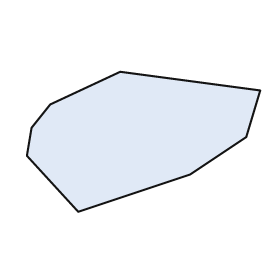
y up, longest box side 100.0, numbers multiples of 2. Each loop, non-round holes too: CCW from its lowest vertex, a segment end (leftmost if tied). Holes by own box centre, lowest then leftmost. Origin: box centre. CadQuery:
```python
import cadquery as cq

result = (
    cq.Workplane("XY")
    .moveTo(-28.0, -30.0)
    .lineTo(20.0, -14.0)
    .lineTo(44.0, 2.0)
    .lineTo(50.0, 22.0)
    .lineTo(-10.0, 30.0)
    .lineTo(-40.0, 16.0)
    .lineTo(-48.0, 6.0)
    .lineTo(-50.0, -6.0)
    .close()
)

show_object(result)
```